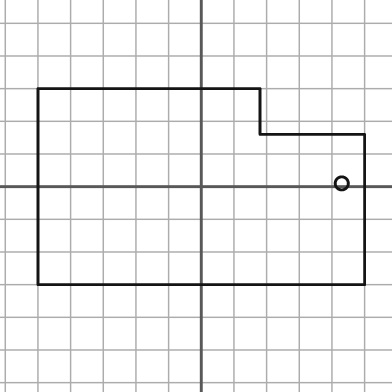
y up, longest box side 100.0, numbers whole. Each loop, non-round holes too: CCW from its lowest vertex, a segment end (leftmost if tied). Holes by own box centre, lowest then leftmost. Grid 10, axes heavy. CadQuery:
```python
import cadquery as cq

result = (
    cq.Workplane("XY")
    .moveTo(-50.0, -30.0)
    .lineTo(50.0, -30.0)
    .lineTo(50.0, 16.0)
    .lineTo(18.0, 16.0)
    .lineTo(18.0, 30.0)
    .lineTo(-50.0, 30.0)
    .close()
    .moveTo(43.0, 1.0)
    .circle(2.0)
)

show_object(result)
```